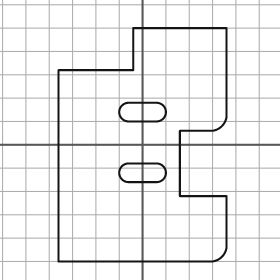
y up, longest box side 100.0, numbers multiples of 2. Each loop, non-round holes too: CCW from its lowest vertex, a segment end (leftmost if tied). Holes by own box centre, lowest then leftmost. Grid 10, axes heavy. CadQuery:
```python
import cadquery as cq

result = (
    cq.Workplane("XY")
    .moveTo(-36.0, -50.0)
    .lineTo(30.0, -50.0)
    .threePointArc((34.0, -48.0), (36.0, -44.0))
    .lineTo(36.0, -22.0)
    .lineTo(16.0, -22.0)
    .lineTo(16.0, 6.0)
    .lineTo(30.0, 6.0)
    .threePointArc((34.0, 8.0), (36.0, 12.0))
    .lineTo(36.0, 50.0)
    .lineTo(-4.0, 50.0)
    .lineTo(-4.0, 32.0)
    .lineTo(-36.0, 32.0)
    .close()
    .moveTo(-6.0, -16.0)
    .lineTo(6.0, -16.0)
    .threePointArc((10.0, -12.0), (6.0, -8.0))
    .lineTo(-6.0, -8.0)
    .threePointArc((-10.0, -12.0), (-6.0, -16.0))
    .close()
    .moveTo(-6.0, 10.0)
    .lineTo(6.0, 10.0)
    .threePointArc((10.0, 14.0), (6.0, 18.0))
    .lineTo(-6.0, 18.0)
    .threePointArc((-10.0, 14.0), (-6.0, 10.0))
    .close()
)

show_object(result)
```